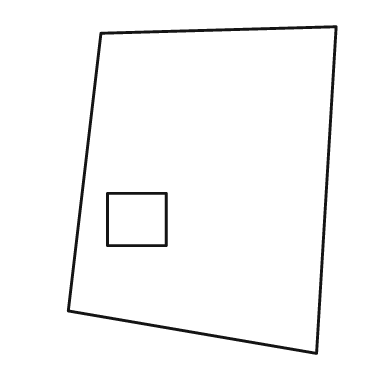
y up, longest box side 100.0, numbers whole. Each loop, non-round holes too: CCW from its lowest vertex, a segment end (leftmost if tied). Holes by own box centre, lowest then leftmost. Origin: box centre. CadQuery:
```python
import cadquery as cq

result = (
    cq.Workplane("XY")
    .moveTo(35.0, -50.0)
    .lineTo(41.0, 50.0)
    .lineTo(-31.0, 48.0)
    .lineTo(-41.0, -37.0)
    .close()
    .moveTo(-29.0, -17.0)
    .lineTo(-11.0, -17.0)
    .lineTo(-11.0, -1.0)
    .lineTo(-29.0, -1.0)
    .close()
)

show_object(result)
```